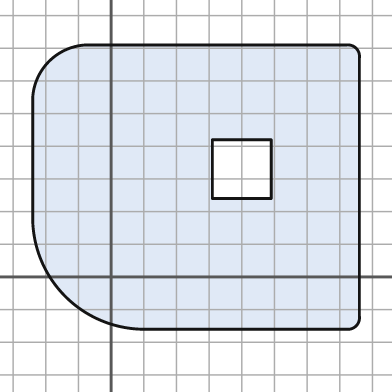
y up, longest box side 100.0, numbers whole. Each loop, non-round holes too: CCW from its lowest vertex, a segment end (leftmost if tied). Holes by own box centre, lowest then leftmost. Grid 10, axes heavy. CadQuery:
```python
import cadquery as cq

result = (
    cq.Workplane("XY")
    .moveTo(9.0, -16.0)
    .lineTo(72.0, -16.0)
    .threePointArc((75.0, -15.0), (76.0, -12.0))
    .lineTo(76.0, 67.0)
    .threePointArc((75.0, 70.0), (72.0, 71.0))
    .lineTo(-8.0, 71.0)
    .threePointArc((-19.0, 66.0), (-24.0, 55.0))
    .lineTo(-24.0, 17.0)
    .threePointArc((-14.0, -6.0), (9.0, -16.0))
    .close()
    .moveTo(31.0, 24.0)
    .lineTo(49.0, 24.0)
    .lineTo(49.0, 42.0)
    .lineTo(31.0, 42.0)
    .close()
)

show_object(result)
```